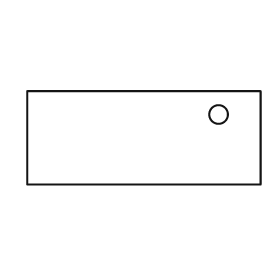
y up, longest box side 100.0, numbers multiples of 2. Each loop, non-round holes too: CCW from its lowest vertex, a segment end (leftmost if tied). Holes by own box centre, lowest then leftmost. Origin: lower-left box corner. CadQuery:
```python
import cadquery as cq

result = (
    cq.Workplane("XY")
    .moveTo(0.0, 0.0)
    .lineTo(100.0, 0.0)
    .lineTo(100.0, 40.0)
    .lineTo(0.0, 40.0)
    .close()
    .moveTo(82.0, 30.0)
    .circle(4.0)
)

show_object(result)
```